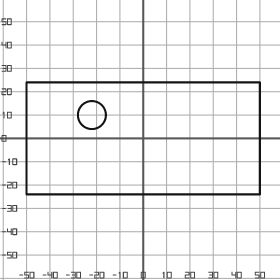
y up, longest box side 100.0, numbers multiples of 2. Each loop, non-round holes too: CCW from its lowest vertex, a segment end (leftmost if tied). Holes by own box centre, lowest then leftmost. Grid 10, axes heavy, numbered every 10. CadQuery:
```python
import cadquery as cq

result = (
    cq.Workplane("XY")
    .moveTo(-50.0, -24.0)
    .lineTo(50.0, -24.0)
    .lineTo(50.0, 24.0)
    .lineTo(-50.0, 24.0)
    .close()
    .moveTo(-22.0, 10.0)
    .circle(6.0)
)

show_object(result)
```